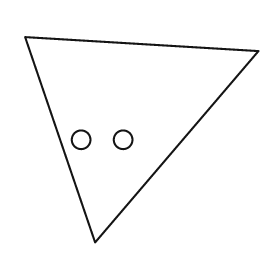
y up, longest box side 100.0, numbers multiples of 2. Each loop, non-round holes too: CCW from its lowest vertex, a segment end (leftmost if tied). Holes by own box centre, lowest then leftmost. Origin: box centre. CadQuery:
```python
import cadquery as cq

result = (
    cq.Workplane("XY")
    .moveTo(-20.0, -44.0)
    .lineTo(50.0, 38.0)
    .lineTo(-50.0, 44.0)
    .close()
    .moveTo(-26.0, 0.0)
    .circle(4.0)
    .moveTo(-8.0, 0.0)
    .circle(4.0)
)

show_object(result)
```